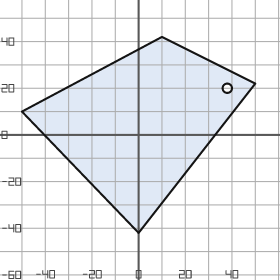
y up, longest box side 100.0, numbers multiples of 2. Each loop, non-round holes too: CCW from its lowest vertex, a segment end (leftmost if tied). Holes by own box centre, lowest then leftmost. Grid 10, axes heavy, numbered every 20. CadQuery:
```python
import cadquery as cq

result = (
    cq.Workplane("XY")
    .moveTo(0.0, -42.0)
    .lineTo(50.0, 22.0)
    .lineTo(10.0, 42.0)
    .lineTo(-50.0, 10.0)
    .close()
    .moveTo(38.0, 20.0)
    .circle(2.0)
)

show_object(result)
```